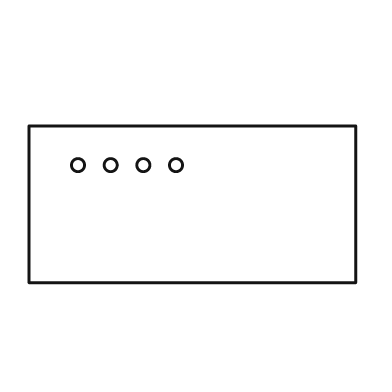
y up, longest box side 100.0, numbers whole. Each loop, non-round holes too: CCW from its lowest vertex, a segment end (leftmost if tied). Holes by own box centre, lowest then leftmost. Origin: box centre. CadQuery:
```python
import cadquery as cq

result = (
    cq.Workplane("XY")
    .moveTo(-50.0, -24.0)
    .lineTo(50.0, -24.0)
    .lineTo(50.0, 24.0)
    .lineTo(-50.0, 24.0)
    .close()
    .moveTo(-35.0, 12.0)
    .circle(2.0)
    .moveTo(-25.0, 12.0)
    .circle(2.0)
    .moveTo(-15.0, 12.0)
    .circle(2.0)
    .moveTo(-5.0, 12.0)
    .circle(2.0)
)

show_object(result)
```